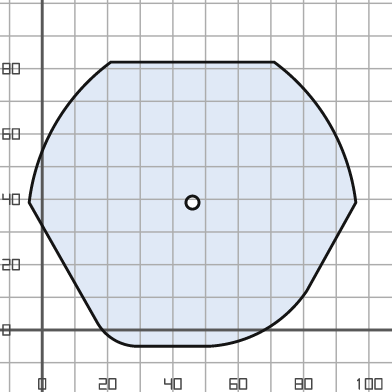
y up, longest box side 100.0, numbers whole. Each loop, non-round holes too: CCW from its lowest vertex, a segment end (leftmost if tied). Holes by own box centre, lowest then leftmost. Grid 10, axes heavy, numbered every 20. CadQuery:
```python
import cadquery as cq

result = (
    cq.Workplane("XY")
    .moveTo(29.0, -5.0)
    .lineTo(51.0, -5.0)
    .threePointArc((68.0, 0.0), (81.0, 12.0))
    .lineTo(96.0, 39.0)
    .threePointArc((88.0, 63.0), (71.0, 82.0))
    .lineTo(21.0, 82.0)
    .threePointArc((4.0, 63.0), (-4.0, 39.0))
    .lineTo(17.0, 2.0)
    .threePointArc((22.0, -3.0), (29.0, -5.0))
    .close()
    .moveTo(46.0, 39.0)
    .circle(2.0)
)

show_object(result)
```